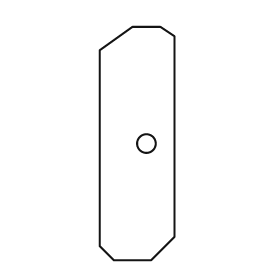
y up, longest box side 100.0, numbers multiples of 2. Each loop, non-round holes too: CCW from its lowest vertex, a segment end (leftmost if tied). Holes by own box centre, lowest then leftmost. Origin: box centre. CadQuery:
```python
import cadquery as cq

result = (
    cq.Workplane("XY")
    .moveTo(-10.0, -50.0)
    .lineTo(6.0, -50.0)
    .lineTo(16.0, -40.0)
    .lineTo(16.0, 46.0)
    .lineTo(10.0, 50.0)
    .lineTo(-2.0, 50.0)
    .lineTo(-16.0, 40.0)
    .lineTo(-16.0, -44.0)
    .close()
    .moveTo(4.0, 0.0)
    .circle(4.0)
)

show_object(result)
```